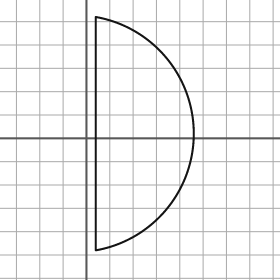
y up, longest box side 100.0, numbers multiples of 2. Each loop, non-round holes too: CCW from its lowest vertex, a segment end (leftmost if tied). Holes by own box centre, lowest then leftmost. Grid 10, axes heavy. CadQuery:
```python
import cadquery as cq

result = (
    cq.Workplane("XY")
    .moveTo(4.0, -48.0)
    .threePointArc((46.0, 2.0), (4.0, 52.0))
    .close()
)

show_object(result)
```